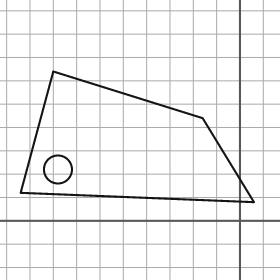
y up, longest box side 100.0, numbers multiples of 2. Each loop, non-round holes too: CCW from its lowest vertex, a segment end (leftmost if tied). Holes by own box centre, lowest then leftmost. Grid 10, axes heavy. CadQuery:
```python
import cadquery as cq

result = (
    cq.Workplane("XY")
    .moveTo(6.0, 8.0)
    .lineTo(-16.0, 44.0)
    .lineTo(-80.0, 64.0)
    .lineTo(-94.0, 12.0)
    .close()
    .moveTo(-78.0, 22.0)
    .circle(6.0)
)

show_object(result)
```